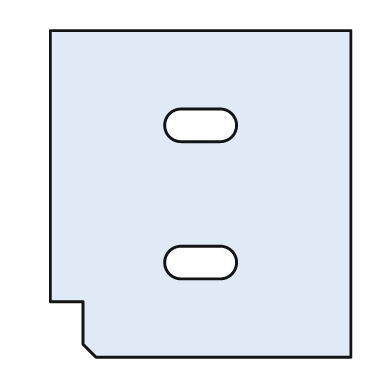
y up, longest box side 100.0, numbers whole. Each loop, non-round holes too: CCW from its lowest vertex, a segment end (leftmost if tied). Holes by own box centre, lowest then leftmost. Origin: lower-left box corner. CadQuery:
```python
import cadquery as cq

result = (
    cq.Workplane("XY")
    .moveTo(14.0, 0.0)
    .lineTo(92.0, 0.0)
    .lineTo(92.0, 100.0)
    .lineTo(0.0, 100.0)
    .lineTo(0.0, 17.0)
    .lineTo(10.0, 17.0)
    .lineTo(10.0, 4.0)
    .close()
    .moveTo(40.0, 24.0)
    .lineTo(52.0, 24.0)
    .threePointArc((57.0, 29.0), (52.0, 34.0))
    .lineTo(40.0, 34.0)
    .threePointArc((35.0, 29.0), (40.0, 24.0))
    .close()
    .moveTo(40.0, 66.0)
    .lineTo(52.0, 66.0)
    .threePointArc((57.0, 71.0), (52.0, 76.0))
    .lineTo(40.0, 76.0)
    .threePointArc((35.0, 71.0), (40.0, 66.0))
    .close()
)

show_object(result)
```